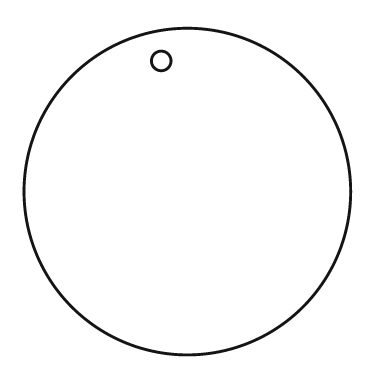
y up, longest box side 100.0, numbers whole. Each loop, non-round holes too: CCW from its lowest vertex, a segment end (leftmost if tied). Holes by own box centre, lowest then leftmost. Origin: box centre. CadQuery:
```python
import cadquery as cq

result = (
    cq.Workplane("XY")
    .moveTo(0.0, 0.0)
    .circle(50.0)
    .moveTo(-8.0, 40.0)
    .circle(3.0)
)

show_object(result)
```